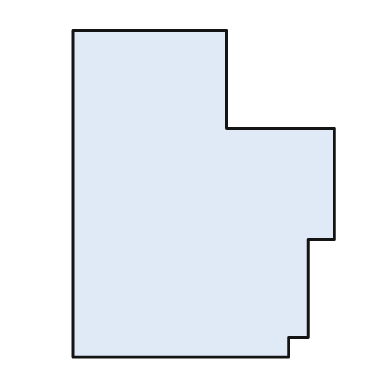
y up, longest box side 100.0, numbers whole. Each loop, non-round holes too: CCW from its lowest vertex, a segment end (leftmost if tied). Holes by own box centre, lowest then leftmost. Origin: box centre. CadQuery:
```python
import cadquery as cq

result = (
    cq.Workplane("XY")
    .moveTo(-40.0, -50.0)
    .lineTo(26.0, -50.0)
    .lineTo(26.0, -44.0)
    .lineTo(32.0, -44.0)
    .lineTo(32.0, -14.0)
    .lineTo(40.0, -14.0)
    .lineTo(40.0, 20.0)
    .lineTo(7.0, 20.0)
    .lineTo(7.0, 50.0)
    .lineTo(-40.0, 50.0)
    .close()
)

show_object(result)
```